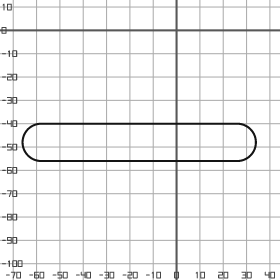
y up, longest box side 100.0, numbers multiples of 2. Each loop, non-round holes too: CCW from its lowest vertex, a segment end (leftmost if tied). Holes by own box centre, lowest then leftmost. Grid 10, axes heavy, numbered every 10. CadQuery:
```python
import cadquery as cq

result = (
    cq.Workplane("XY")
    .moveTo(-58.0, -56.0)
    .lineTo(26.0, -56.0)
    .threePointArc((34.0, -48.0), (26.0, -40.0))
    .lineTo(-58.0, -40.0)
    .threePointArc((-66.0, -48.0), (-58.0, -56.0))
    .close()
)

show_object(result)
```